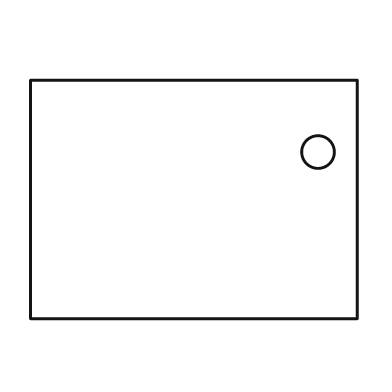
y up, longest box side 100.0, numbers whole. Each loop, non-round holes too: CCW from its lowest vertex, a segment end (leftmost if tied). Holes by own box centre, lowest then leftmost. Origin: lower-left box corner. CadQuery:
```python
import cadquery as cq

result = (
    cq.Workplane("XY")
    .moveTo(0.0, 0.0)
    .lineTo(100.0, 0.0)
    .lineTo(100.0, 73.0)
    .lineTo(0.0, 73.0)
    .close()
    .moveTo(88.0, 51.0)
    .circle(5.0)
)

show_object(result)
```